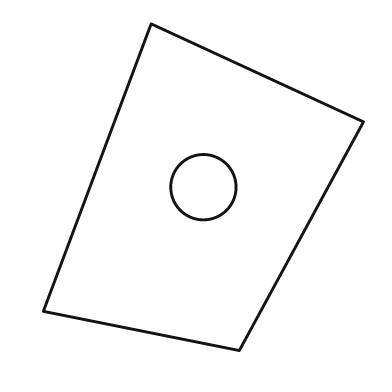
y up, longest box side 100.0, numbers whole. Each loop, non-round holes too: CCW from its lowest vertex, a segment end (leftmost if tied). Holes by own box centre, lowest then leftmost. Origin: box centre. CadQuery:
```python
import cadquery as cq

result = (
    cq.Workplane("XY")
    .moveTo(11.0, -50.0)
    .lineTo(49.0, 20.0)
    .lineTo(-16.0, 50.0)
    .lineTo(-49.0, -38.0)
    .close()
    .moveTo(0.0, 0.0)
    .circle(10.0)
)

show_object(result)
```